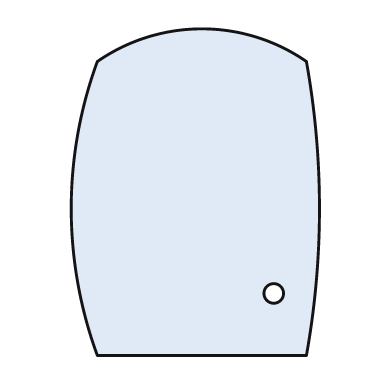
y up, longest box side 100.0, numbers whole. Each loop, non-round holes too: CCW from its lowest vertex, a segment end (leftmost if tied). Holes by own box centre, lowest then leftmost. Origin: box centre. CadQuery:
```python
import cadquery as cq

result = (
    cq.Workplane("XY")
    .moveTo(-30.0, -50.0)
    .lineTo(34.0, -50.0)
    .threePointArc((38.0, -5.0), (34.0, 40.0))
    .threePointArc((2.0, 50.0), (-30.0, 40.0))
    .threePointArc((-38.0, -5.0), (-30.0, -50.0))
    .close()
    .moveTo(24.0, -31.0)
    .circle(3.0)
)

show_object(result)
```